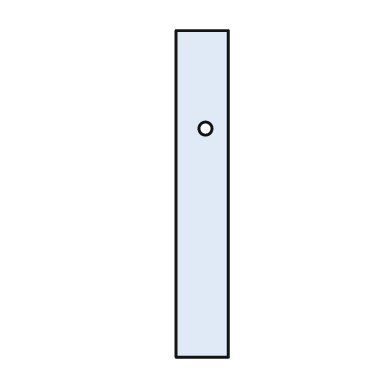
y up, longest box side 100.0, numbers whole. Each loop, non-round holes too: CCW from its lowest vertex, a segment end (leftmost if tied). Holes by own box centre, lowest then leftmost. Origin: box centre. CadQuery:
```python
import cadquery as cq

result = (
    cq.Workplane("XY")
    .moveTo(-8.0, -50.0)
    .lineTo(8.0, -50.0)
    .lineTo(8.0, 50.0)
    .lineTo(-8.0, 50.0)
    .close()
    .moveTo(1.0, 20.0)
    .circle(2.0)
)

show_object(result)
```